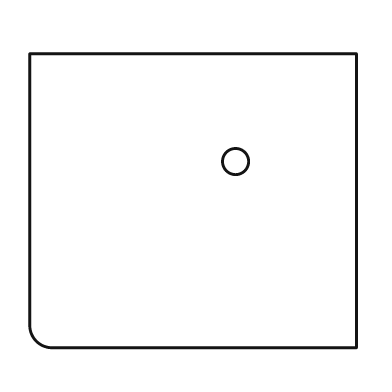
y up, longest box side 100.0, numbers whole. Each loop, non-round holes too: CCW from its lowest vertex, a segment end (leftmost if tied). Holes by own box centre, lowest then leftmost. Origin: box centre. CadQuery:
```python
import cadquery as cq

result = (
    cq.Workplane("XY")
    .moveTo(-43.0, -45.0)
    .lineTo(50.0, -45.0)
    .lineTo(50.0, 45.0)
    .lineTo(-50.0, 45.0)
    .lineTo(-50.0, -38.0)
    .threePointArc((-48.0, -43.0), (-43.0, -45.0))
    .close()
    .moveTo(13.0, 12.0)
    .circle(4.0)
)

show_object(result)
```